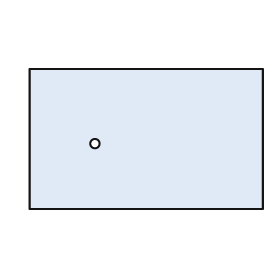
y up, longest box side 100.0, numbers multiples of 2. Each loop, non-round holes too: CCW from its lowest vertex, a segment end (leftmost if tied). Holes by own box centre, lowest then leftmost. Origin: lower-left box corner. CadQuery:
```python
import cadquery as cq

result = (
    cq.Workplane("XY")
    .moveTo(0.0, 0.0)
    .lineTo(100.0, 0.0)
    .lineTo(100.0, 60.0)
    .lineTo(0.0, 60.0)
    .close()
    .moveTo(28.0, 28.0)
    .circle(2.0)
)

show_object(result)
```